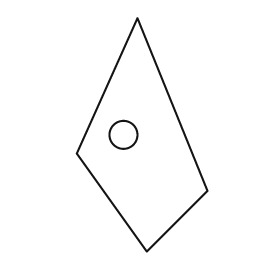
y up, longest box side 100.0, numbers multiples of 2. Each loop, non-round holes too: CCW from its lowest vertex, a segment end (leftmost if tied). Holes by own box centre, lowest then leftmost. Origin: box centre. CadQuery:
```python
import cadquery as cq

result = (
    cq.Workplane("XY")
    .moveTo(2.0, -50.0)
    .lineTo(28.0, -24.0)
    .lineTo(-2.0, 50.0)
    .lineTo(-28.0, -8.0)
    .close()
    .moveTo(-8.0, 0.0)
    .circle(6.0)
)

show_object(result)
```